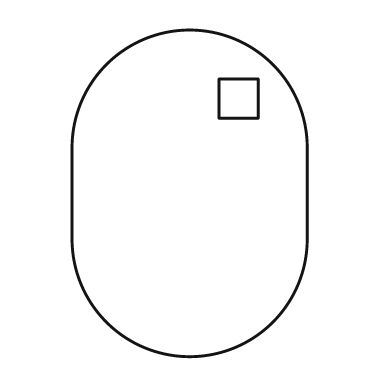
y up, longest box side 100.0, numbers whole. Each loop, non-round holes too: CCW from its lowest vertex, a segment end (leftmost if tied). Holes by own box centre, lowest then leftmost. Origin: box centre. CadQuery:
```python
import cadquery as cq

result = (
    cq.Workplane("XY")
    .moveTo(-36.0, -14.0)
    .threePointArc((0.0, -50.0), (36.0, -14.0))
    .lineTo(36.0, 14.0)
    .threePointArc((0.0, 50.0), (-36.0, 14.0))
    .close()
    .moveTo(9.0, 23.0)
    .lineTo(21.0, 23.0)
    .lineTo(21.0, 35.0)
    .lineTo(9.0, 35.0)
    .close()
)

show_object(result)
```